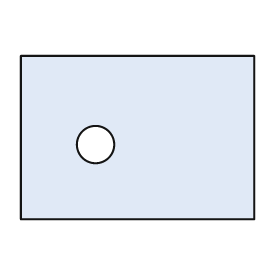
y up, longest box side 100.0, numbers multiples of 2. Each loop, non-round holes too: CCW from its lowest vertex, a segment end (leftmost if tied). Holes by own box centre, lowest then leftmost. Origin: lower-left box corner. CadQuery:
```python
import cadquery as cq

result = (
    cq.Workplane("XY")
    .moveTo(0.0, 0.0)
    .lineTo(100.0, 0.0)
    .lineTo(100.0, 70.0)
    .lineTo(0.0, 70.0)
    .close()
    .moveTo(32.0, 32.0)
    .circle(8.0)
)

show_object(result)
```